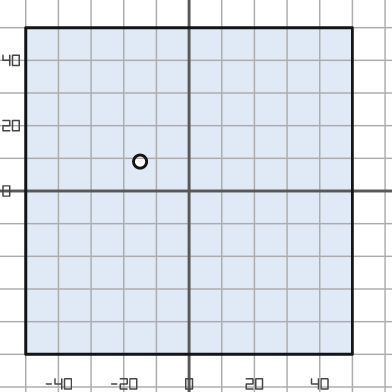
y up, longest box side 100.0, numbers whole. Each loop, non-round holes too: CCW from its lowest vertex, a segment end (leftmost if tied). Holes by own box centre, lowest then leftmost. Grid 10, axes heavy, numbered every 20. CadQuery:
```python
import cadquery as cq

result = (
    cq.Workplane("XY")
    .moveTo(-50.0, -50.0)
    .lineTo(50.0, -50.0)
    .lineTo(50.0, 50.0)
    .lineTo(-50.0, 50.0)
    .close()
    .moveTo(-15.0, 9.0)
    .circle(2.0)
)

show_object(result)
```